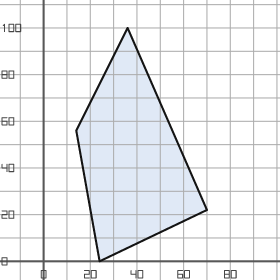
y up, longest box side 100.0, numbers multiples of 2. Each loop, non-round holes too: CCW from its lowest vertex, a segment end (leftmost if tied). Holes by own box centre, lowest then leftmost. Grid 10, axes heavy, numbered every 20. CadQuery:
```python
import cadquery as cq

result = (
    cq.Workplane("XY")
    .moveTo(24.0, 0.0)
    .lineTo(70.0, 22.0)
    .lineTo(36.0, 100.0)
    .lineTo(14.0, 56.0)
    .close()
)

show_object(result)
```